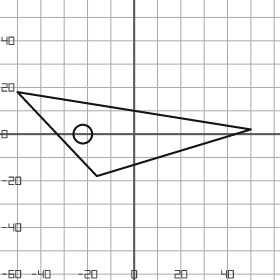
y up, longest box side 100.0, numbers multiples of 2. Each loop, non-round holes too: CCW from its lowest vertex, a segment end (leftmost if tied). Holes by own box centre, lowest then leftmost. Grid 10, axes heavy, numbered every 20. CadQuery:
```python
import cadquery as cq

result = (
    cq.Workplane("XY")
    .moveTo(-16.0, -18.0)
    .lineTo(50.0, 2.0)
    .lineTo(-50.0, 18.0)
    .close()
    .moveTo(-22.0, 0.0)
    .circle(4.0)
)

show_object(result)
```